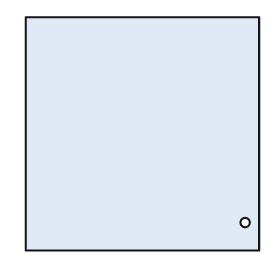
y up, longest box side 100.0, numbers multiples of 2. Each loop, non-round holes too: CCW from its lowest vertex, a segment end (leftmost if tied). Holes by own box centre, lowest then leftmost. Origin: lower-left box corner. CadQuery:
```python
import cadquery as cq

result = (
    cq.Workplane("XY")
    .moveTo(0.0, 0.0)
    .lineTo(100.0, 0.0)
    .lineTo(100.0, 100.0)
    .lineTo(0.0, 100.0)
    .close()
    .moveTo(94.0, 12.0)
    .circle(2.0)
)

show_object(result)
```